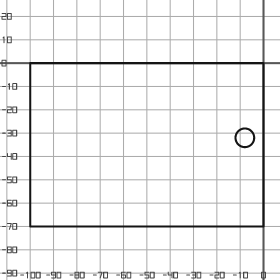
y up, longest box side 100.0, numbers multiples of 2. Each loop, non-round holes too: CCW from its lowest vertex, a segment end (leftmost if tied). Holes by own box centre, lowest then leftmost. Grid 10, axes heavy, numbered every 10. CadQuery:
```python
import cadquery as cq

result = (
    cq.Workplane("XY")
    .moveTo(-100.0, -70.0)
    .lineTo(0.0, -70.0)
    .lineTo(0.0, 0.0)
    .lineTo(-100.0, 0.0)
    .close()
    .moveTo(-8.0, -32.0)
    .circle(4.0)
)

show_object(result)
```